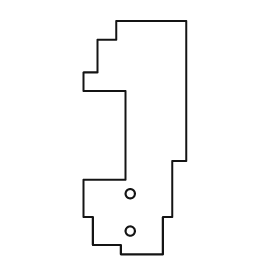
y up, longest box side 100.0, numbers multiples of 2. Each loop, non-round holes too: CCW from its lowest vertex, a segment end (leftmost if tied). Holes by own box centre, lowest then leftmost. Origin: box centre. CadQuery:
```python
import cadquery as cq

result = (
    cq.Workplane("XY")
    .moveTo(-6.0, -50.0)
    .lineTo(12.0, -50.0)
    .lineTo(12.0, -34.0)
    .lineTo(16.0, -34.0)
    .lineTo(16.0, -10.0)
    .lineTo(22.0, -10.0)
    .lineTo(22.0, 50.0)
    .lineTo(-8.0, 50.0)
    .lineTo(-8.0, 42.0)
    .lineTo(-16.0, 42.0)
    .lineTo(-16.0, 28.0)
    .lineTo(-22.0, 28.0)
    .lineTo(-22.0, 20.0)
    .lineTo(-4.0, 20.0)
    .lineTo(-4.0, -18.0)
    .lineTo(-22.0, -18.0)
    .lineTo(-22.0, -34.0)
    .lineTo(-18.0, -34.0)
    .lineTo(-18.0, -46.0)
    .lineTo(-6.0, -46.0)
    .close()
    .moveTo(-2.0, -40.0)
    .circle(2.0)
    .moveTo(-2.0, -24.0)
    .circle(2.0)
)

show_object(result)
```